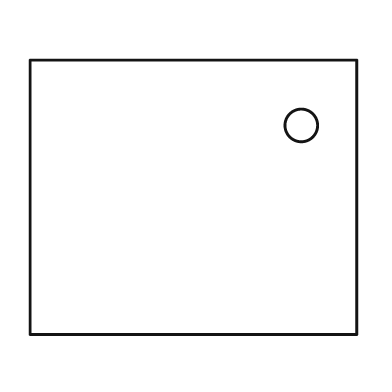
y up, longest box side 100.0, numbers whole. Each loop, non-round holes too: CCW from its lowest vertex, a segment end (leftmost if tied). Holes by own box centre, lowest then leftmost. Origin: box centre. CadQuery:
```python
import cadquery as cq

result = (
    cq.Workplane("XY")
    .moveTo(-50.0, -42.0)
    .lineTo(50.0, -42.0)
    .lineTo(50.0, 42.0)
    .lineTo(-50.0, 42.0)
    .close()
    .moveTo(33.0, 22.0)
    .circle(5.0)
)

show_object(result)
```